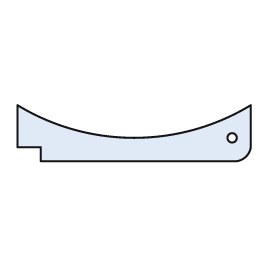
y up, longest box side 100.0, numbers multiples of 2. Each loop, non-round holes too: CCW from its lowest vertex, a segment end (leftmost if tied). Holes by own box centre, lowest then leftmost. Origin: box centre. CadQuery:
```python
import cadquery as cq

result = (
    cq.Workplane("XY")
    .moveTo(-40.0, -12.0)
    .lineTo(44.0, -12.0)
    .threePointArc((48.0, -10.0), (50.0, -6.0))
    .lineTo(50.0, 12.0)
    .threePointArc((0.0, -2.0), (-50.0, 12.0))
    .lineTo(-50.0, -6.0)
    .lineTo(-40.0, -6.0)
    .close()
    .moveTo(42.0, -2.0)
    .circle(2.0)
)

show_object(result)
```